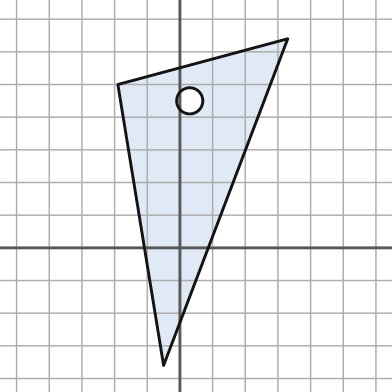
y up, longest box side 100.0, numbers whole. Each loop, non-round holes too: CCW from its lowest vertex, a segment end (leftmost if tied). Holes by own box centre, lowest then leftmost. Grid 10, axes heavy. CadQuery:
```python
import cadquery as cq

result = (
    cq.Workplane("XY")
    .moveTo(-5.0, -36.0)
    .lineTo(33.0, 64.0)
    .lineTo(-19.0, 50.0)
    .close()
    .moveTo(3.0, 45.0)
    .circle(4.0)
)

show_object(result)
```